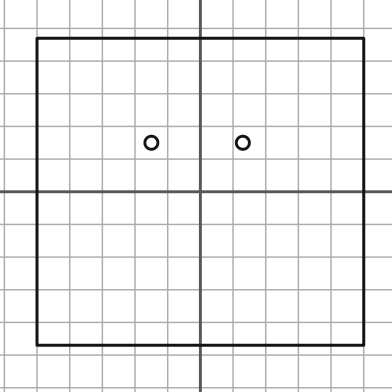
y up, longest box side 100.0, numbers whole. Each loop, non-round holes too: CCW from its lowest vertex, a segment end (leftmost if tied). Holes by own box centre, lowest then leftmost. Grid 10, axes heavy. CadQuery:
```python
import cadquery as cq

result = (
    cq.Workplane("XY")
    .moveTo(-50.0, -47.0)
    .lineTo(50.0, -47.0)
    .lineTo(50.0, 47.0)
    .lineTo(-50.0, 47.0)
    .close()
    .moveTo(-15.0, 15.0)
    .circle(2.0)
    .moveTo(13.0, 15.0)
    .circle(2.0)
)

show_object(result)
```